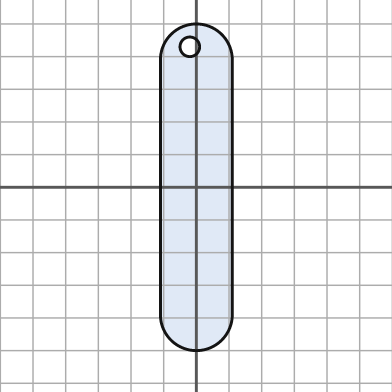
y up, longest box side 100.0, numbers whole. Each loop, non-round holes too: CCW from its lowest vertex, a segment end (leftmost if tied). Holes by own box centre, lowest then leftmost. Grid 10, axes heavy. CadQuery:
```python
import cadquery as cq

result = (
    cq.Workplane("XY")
    .moveTo(-11.0, -39.0)
    .threePointArc((0.0, -50.0), (11.0, -39.0))
    .lineTo(11.0, 39.0)
    .threePointArc((0.0, 50.0), (-11.0, 39.0))
    .close()
    .moveTo(-2.0, 43.0)
    .circle(3.0)
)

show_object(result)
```